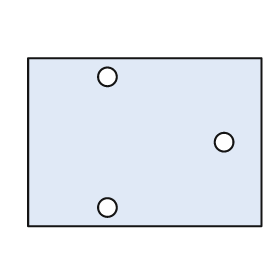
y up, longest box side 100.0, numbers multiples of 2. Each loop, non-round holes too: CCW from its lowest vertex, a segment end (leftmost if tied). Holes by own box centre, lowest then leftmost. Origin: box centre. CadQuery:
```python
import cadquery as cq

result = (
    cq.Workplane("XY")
    .moveTo(-50.0, -36.0)
    .lineTo(50.0, -36.0)
    .lineTo(50.0, 36.0)
    .lineTo(-50.0, 36.0)
    .close()
    .moveTo(-16.0, -28.0)
    .circle(4.0)
    .moveTo(34.0, 0.0)
    .circle(4.0)
    .moveTo(-16.0, 28.0)
    .circle(4.0)
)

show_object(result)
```